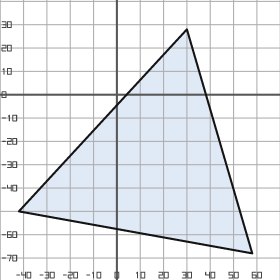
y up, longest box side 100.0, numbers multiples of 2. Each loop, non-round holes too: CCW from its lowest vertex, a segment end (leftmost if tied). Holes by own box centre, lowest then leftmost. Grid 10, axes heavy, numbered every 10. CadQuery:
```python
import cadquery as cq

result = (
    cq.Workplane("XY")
    .moveTo(58.0, -68.0)
    .lineTo(30.0, 28.0)
    .lineTo(-42.0, -50.0)
    .close()
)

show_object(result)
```